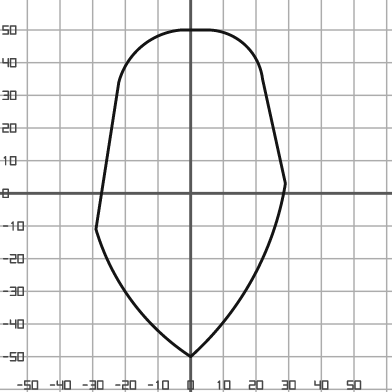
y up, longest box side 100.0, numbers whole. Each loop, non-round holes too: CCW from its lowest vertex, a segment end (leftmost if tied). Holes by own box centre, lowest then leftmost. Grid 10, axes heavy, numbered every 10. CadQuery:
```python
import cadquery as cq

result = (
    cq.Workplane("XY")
    .moveTo(0.0, -50.0)
    .threePointArc((19.0, -26.0), (29.0, 3.0))
    .lineTo(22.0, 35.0)
    .threePointArc((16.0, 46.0), (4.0, 50.0))
    .lineTo(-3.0, 50.0)
    .threePointArc((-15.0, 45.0), (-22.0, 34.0))
    .lineTo(-29.0, -11.0)
    .threePointArc((-18.0, -33.0), (0.0, -50.0))
    .close()
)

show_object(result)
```